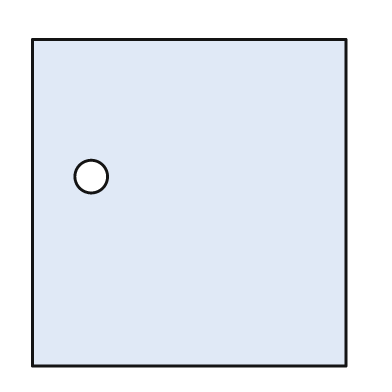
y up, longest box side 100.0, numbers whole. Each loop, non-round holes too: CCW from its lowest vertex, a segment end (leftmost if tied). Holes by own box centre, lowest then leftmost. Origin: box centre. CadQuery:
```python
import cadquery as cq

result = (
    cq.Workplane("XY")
    .moveTo(-48.0, -50.0)
    .lineTo(48.0, -50.0)
    .lineTo(48.0, 50.0)
    .lineTo(-48.0, 50.0)
    .close()
    .moveTo(-30.0, 8.0)
    .circle(5.0)
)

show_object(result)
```